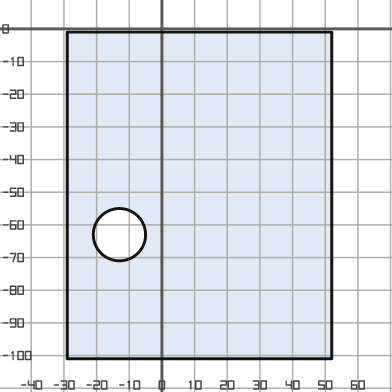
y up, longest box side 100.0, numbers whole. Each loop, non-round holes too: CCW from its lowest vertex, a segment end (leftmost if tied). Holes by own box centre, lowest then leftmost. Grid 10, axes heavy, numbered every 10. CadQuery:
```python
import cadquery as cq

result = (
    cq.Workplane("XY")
    .moveTo(-29.0, -101.0)
    .lineTo(52.0, -101.0)
    .lineTo(52.0, -1.0)
    .lineTo(-29.0, -1.0)
    .close()
    .moveTo(-13.0, -63.0)
    .circle(8.0)
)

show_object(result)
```